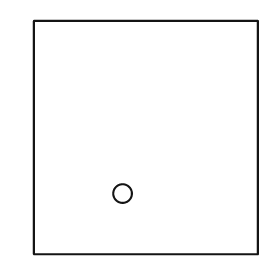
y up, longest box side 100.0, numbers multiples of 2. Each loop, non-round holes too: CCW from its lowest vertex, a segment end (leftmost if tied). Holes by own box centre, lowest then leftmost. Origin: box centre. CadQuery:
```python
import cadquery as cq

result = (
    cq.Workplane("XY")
    .moveTo(-48.0, -50.0)
    .lineTo(48.0, -50.0)
    .lineTo(48.0, 50.0)
    .lineTo(-48.0, 50.0)
    .close()
    .moveTo(-10.0, -24.0)
    .circle(4.0)
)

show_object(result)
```